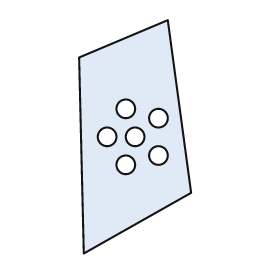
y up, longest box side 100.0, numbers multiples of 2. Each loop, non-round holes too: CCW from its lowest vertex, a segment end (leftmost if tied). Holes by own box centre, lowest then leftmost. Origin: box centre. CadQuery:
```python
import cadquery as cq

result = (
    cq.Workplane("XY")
    .moveTo(-22.0, -50.0)
    .lineTo(24.0, -24.0)
    .lineTo(14.0, 50.0)
    .lineTo(-24.0, 34.0)
    .close()
    .moveTo(-4.0, -12.0)
    .circle(4.0)
    .moveTo(10.0, -8.0)
    .circle(4.0)
    .moveTo(-12.0, 0.0)
    .circle(4.0)
    .moveTo(0.0, 0.0)
    .circle(4.0)
    .moveTo(10.0, 8.0)
    .circle(4.0)
    .moveTo(-4.0, 12.0)
    .circle(4.0)
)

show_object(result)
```